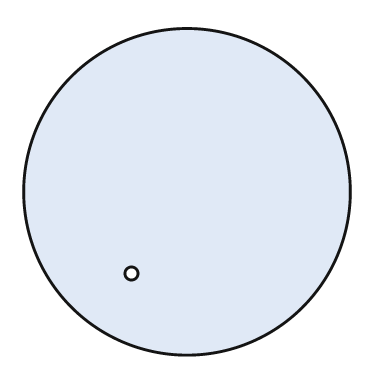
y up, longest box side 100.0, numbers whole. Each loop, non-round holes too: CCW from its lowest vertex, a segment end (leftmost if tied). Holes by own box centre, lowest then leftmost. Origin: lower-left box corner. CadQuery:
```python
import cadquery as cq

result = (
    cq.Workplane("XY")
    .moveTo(50.0, 50.0)
    .circle(50.0)
    .moveTo(33.0, 25.0)
    .circle(2.0)
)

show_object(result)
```